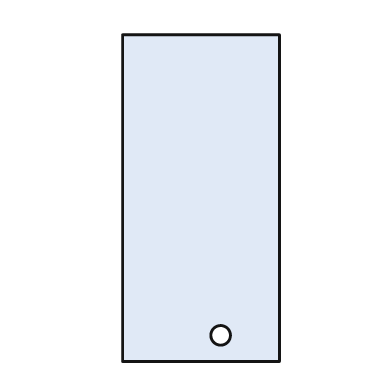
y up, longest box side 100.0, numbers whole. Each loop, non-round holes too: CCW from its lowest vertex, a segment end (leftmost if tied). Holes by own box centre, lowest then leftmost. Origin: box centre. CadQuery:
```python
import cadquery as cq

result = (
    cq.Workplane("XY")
    .moveTo(-24.0, -50.0)
    .lineTo(24.0, -50.0)
    .lineTo(24.0, 50.0)
    .lineTo(-24.0, 50.0)
    .close()
    .moveTo(6.0, -42.0)
    .circle(3.0)
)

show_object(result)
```